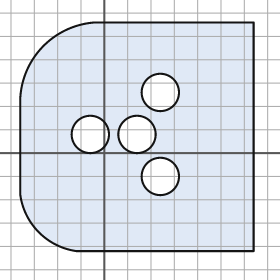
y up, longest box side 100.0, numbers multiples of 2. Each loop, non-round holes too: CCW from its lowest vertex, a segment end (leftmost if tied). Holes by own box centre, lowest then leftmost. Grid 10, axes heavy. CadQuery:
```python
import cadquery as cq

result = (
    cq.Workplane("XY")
    .moveTo(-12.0, -42.0)
    .lineTo(64.0, -42.0)
    .lineTo(64.0, 56.0)
    .lineTo(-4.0, 56.0)
    .threePointArc((-26.0, 46.0), (-36.0, 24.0))
    .lineTo(-36.0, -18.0)
    .threePointArc((-28.0, -34.0), (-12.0, -42.0))
    .close()
    .moveTo(24.0, -10.0)
    .circle(8.0)
    .moveTo(-6.0, 8.0)
    .circle(8.0)
    .moveTo(14.0, 8.0)
    .circle(8.0)
    .moveTo(24.0, 26.0)
    .circle(8.0)
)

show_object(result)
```